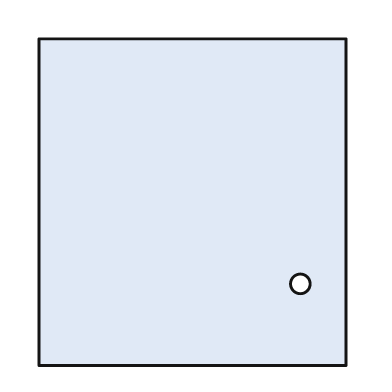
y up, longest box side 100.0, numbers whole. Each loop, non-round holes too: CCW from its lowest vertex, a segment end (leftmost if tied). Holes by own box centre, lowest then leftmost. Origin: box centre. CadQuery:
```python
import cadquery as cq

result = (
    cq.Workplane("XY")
    .moveTo(-47.0, -50.0)
    .lineTo(47.0, -50.0)
    .lineTo(47.0, 50.0)
    .lineTo(-47.0, 50.0)
    .close()
    .moveTo(33.0, -25.0)
    .circle(3.0)
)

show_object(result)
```